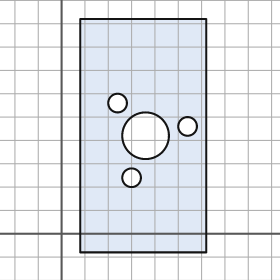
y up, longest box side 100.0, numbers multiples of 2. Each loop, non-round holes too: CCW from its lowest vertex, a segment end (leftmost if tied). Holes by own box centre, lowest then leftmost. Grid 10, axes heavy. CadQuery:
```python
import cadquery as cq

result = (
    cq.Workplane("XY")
    .moveTo(8.0, -8.0)
    .lineTo(62.0, -8.0)
    .lineTo(62.0, 92.0)
    .lineTo(8.0, 92.0)
    .close()
    .moveTo(30.0, 24.0)
    .circle(4.0)
    .moveTo(36.0, 42.0)
    .circle(10.0)
    .moveTo(54.0, 46.0)
    .circle(4.0)
    .moveTo(24.0, 56.0)
    .circle(4.0)
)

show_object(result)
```